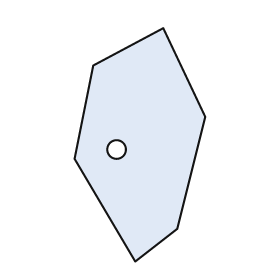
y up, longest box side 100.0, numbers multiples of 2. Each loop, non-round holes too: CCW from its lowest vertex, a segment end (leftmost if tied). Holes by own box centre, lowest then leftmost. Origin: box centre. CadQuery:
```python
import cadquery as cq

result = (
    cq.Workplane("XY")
    .moveTo(-2.0, -50.0)
    .lineTo(16.0, -36.0)
    .lineTo(28.0, 12.0)
    .lineTo(10.0, 50.0)
    .lineTo(-20.0, 34.0)
    .lineTo(-28.0, -6.0)
    .close()
    .moveTo(-10.0, -2.0)
    .circle(4.0)
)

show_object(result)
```